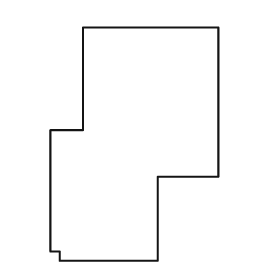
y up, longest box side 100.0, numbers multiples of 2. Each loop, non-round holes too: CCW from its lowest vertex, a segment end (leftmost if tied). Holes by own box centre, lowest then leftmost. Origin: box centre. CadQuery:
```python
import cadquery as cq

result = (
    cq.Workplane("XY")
    .moveTo(-32.0, -50.0)
    .lineTo(10.0, -50.0)
    .lineTo(10.0, -14.0)
    .lineTo(36.0, -14.0)
    .lineTo(36.0, 50.0)
    .lineTo(-22.0, 50.0)
    .lineTo(-22.0, 6.0)
    .lineTo(-36.0, 6.0)
    .lineTo(-36.0, -46.0)
    .lineTo(-32.0, -46.0)
    .close()
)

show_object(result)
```